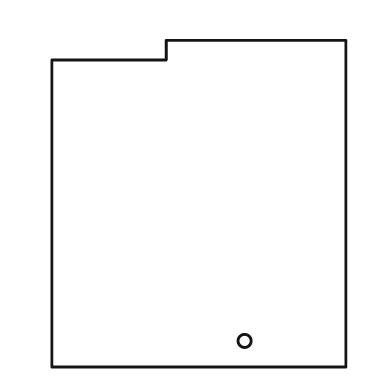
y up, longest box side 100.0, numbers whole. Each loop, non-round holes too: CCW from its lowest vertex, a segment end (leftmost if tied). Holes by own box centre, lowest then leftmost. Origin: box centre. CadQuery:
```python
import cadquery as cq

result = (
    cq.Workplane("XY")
    .moveTo(-45.0, -50.0)
    .lineTo(45.0, -50.0)
    .lineTo(45.0, 50.0)
    .lineTo(-10.0, 50.0)
    .lineTo(-10.0, 44.0)
    .lineTo(-45.0, 44.0)
    .close()
    .moveTo(14.0, -42.0)
    .circle(2.0)
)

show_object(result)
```